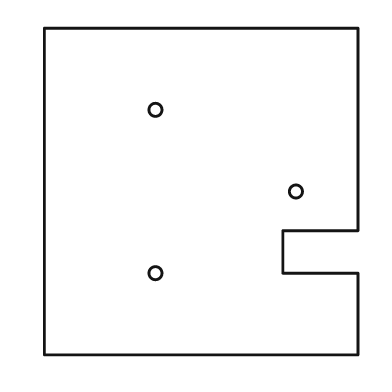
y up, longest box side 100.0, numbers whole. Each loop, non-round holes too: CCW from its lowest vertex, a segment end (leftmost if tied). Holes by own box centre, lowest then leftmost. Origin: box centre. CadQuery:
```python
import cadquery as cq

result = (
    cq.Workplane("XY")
    .moveTo(-48.0, -50.0)
    .lineTo(48.0, -50.0)
    .lineTo(48.0, -25.0)
    .lineTo(25.0, -25.0)
    .lineTo(25.0, -12.0)
    .lineTo(48.0, -12.0)
    .lineTo(48.0, 50.0)
    .lineTo(-48.0, 50.0)
    .close()
    .moveTo(-14.0, -25.0)
    .circle(2.0)
    .moveTo(29.0, 0.0)
    .circle(2.0)
    .moveTo(-14.0, 25.0)
    .circle(2.0)
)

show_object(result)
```